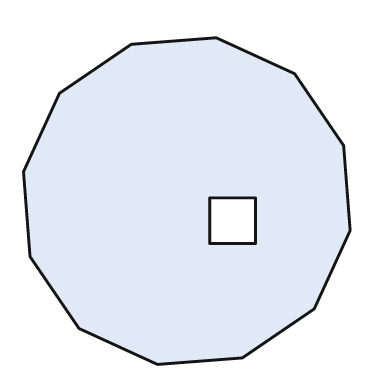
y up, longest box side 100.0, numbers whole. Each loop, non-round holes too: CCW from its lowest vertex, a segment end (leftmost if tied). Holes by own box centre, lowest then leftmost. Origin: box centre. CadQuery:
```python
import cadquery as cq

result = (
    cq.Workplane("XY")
    .moveTo(-9.0, -50.0)
    .lineTo(17.0, -48.0)
    .lineTo(39.0, -33.0)
    .lineTo(50.0, -9.0)
    .lineTo(48.0, 17.0)
    .lineTo(33.0, 39.0)
    .lineTo(9.0, 50.0)
    .lineTo(-17.0, 48.0)
    .lineTo(-39.0, 33.0)
    .lineTo(-50.0, 9.0)
    .lineTo(-48.0, -17.0)
    .lineTo(-33.0, -39.0)
    .close()
    .moveTo(7.0, -13.0)
    .lineTo(21.0, -13.0)
    .lineTo(21.0, 1.0)
    .lineTo(7.0, 1.0)
    .close()
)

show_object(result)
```